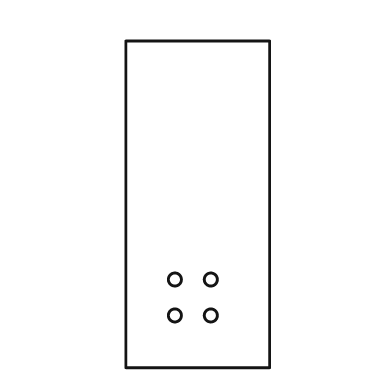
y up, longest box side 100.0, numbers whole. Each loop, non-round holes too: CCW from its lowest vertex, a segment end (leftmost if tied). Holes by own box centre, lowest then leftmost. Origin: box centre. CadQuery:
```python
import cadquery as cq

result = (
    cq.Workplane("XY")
    .moveTo(-22.0, -50.0)
    .lineTo(22.0, -50.0)
    .lineTo(22.0, 50.0)
    .lineTo(-22.0, 50.0)
    .close()
    .moveTo(-7.0, -34.0)
    .circle(2.0)
    .moveTo(4.0, -34.0)
    .circle(2.0)
    .moveTo(-7.0, -23.0)
    .circle(2.0)
    .moveTo(4.0, -23.0)
    .circle(2.0)
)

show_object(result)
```